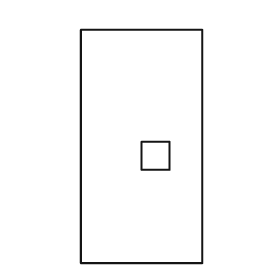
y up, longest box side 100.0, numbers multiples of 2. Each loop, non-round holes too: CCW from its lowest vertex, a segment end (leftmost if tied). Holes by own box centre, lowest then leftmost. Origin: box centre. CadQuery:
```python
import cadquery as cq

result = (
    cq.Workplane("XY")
    .moveTo(-26.0, -50.0)
    .lineTo(26.0, -50.0)
    .lineTo(26.0, 50.0)
    .lineTo(-26.0, 50.0)
    .close()
    .moveTo(0.0, -10.0)
    .lineTo(12.0, -10.0)
    .lineTo(12.0, 2.0)
    .lineTo(0.0, 2.0)
    .close()
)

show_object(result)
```